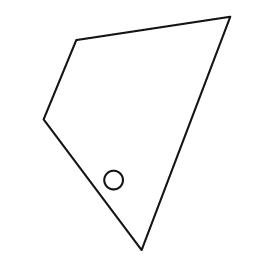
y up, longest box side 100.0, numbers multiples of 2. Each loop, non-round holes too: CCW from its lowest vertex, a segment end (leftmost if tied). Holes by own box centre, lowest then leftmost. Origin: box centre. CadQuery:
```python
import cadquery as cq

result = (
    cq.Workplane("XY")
    .moveTo(2.0, -50.0)
    .lineTo(40.0, 50.0)
    .lineTo(-26.0, 40.0)
    .lineTo(-40.0, 6.0)
    .close()
    .moveTo(-10.0, -20.0)
    .circle(4.0)
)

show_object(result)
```